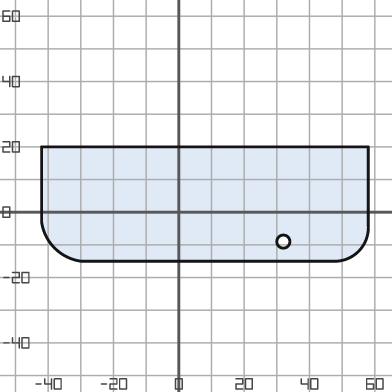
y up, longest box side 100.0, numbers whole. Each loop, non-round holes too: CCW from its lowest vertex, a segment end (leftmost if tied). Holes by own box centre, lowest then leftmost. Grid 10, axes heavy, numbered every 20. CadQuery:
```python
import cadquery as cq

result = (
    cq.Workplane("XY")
    .moveTo(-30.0, -15.0)
    .lineTo(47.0, -15.0)
    .threePointArc((55.0, -12.0), (58.0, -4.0))
    .lineTo(58.0, 20.0)
    .lineTo(-42.0, 20.0)
    .lineTo(-42.0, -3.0)
    .threePointArc((-38.0, -11.0), (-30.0, -15.0))
    .close()
    .moveTo(32.0, -9.0)
    .circle(2.0)
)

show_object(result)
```